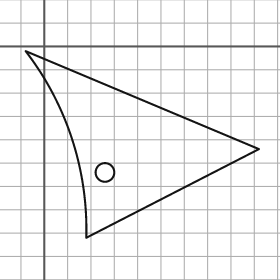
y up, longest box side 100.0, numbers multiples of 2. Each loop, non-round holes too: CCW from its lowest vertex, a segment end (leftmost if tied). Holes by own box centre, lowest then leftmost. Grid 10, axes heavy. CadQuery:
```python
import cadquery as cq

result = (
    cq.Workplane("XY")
    .moveTo(18.0, -82.0)
    .lineTo(92.0, -44.0)
    .lineTo(-8.0, -2.0)
    .threePointArc((12.0, -40.0), (18.0, -82.0))
    .close()
    .moveTo(26.0, -54.0)
    .circle(4.0)
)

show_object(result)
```